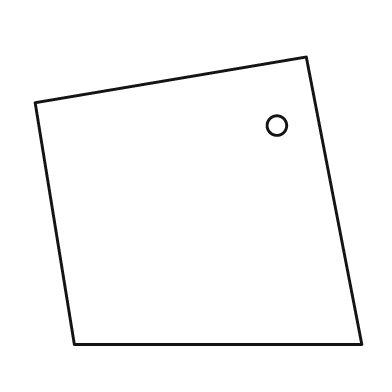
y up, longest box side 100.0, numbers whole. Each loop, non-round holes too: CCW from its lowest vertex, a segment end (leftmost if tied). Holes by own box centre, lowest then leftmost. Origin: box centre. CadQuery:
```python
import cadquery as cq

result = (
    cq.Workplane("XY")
    .moveTo(-38.0, -44.0)
    .lineTo(50.0, -44.0)
    .lineTo(33.0, 44.0)
    .lineTo(-50.0, 30.0)
    .close()
    .moveTo(24.0, 23.0)
    .circle(3.0)
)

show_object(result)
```